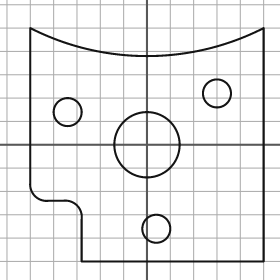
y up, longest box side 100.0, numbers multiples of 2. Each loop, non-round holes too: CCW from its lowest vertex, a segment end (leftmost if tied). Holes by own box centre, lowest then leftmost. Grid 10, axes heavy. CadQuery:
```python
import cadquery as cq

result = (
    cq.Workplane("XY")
    .moveTo(-28.0, -50.0)
    .lineTo(50.0, -50.0)
    .lineTo(50.0, 50.0)
    .threePointArc((0.0, 38.0), (-50.0, 50.0))
    .lineTo(-50.0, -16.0)
    .threePointArc((-48.0, -22.0), (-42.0, -24.0))
    .lineTo(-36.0, -24.0)
    .threePointArc((-30.0, -26.0), (-28.0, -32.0))
    .close()
    .moveTo(4.0, -36.0)
    .circle(6.0)
    .moveTo(0.0, 0.0)
    .circle(14.0)
    .moveTo(-34.0, 14.0)
    .circle(6.0)
    .moveTo(30.0, 22.0)
    .circle(6.0)
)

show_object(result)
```